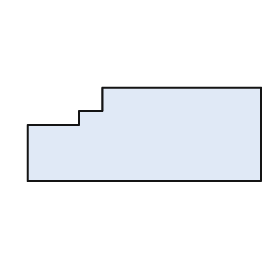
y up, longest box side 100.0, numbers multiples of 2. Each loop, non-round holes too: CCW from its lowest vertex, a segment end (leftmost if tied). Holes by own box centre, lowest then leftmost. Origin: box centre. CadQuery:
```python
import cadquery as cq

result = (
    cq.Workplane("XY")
    .moveTo(-50.0, -20.0)
    .lineTo(50.0, -20.0)
    .lineTo(50.0, 20.0)
    .lineTo(-18.0, 20.0)
    .lineTo(-18.0, 10.0)
    .lineTo(-28.0, 10.0)
    .lineTo(-28.0, 4.0)
    .lineTo(-50.0, 4.0)
    .close()
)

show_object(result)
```